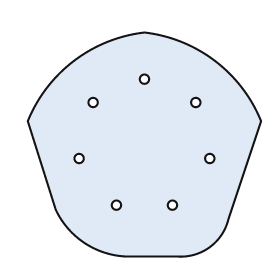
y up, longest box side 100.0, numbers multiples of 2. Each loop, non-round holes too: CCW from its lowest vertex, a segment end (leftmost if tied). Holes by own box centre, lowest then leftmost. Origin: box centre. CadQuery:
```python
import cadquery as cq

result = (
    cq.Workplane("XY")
    .moveTo(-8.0, -48.0)
    .lineTo(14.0, -48.0)
    .threePointArc((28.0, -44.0), (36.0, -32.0))
    .lineTo(50.0, 10.0)
    .threePointArc((30.0, 36.0), (0.0, 48.0))
    .threePointArc((-30.0, 36.0), (-50.0, 10.0))
    .lineTo(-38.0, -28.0)
    .threePointArc((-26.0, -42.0), (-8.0, -48.0))
    .close()
    .moveTo(-12.0, -26.0)
    .circle(2.0)
    .moveTo(12.0, -26.0)
    .circle(2.0)
    .moveTo(-28.0, -6.0)
    .circle(2.0)
    .moveTo(28.0, -6.0)
    .circle(2.0)
    .moveTo(-22.0, 18.0)
    .circle(2.0)
    .moveTo(22.0, 18.0)
    .circle(2.0)
    .moveTo(0.0, 28.0)
    .circle(2.0)
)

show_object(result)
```